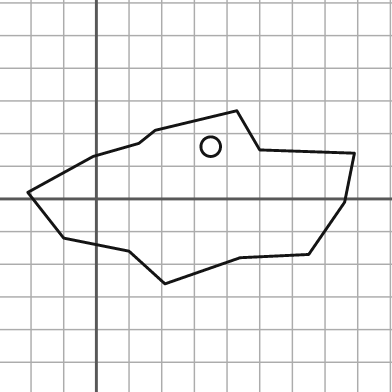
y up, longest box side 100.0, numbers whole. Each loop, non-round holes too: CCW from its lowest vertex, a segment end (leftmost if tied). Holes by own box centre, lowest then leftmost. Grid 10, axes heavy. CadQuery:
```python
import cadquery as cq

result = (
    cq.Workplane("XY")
    .moveTo(21.0, -26.0)
    .lineTo(44.0, -18.0)
    .lineTo(65.0, -17.0)
    .lineTo(76.0, -1.0)
    .lineTo(79.0, 14.0)
    .lineTo(50.0, 15.0)
    .lineTo(43.0, 27.0)
    .lineTo(18.0, 21.0)
    .lineTo(13.0, 17.0)
    .lineTo(-1.0, 13.0)
    .lineTo(-21.0, 2.0)
    .lineTo(-10.0, -12.0)
    .lineTo(10.0, -16.0)
    .close()
    .moveTo(35.0, 16.0)
    .circle(3.0)
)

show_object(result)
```